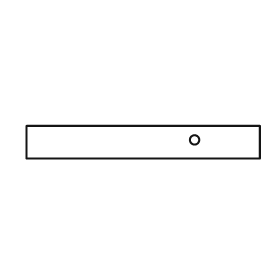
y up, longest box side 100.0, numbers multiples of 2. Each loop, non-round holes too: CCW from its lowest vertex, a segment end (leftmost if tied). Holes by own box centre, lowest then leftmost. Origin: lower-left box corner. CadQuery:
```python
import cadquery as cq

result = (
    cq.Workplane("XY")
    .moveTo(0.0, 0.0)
    .lineTo(100.0, 0.0)
    .lineTo(100.0, 14.0)
    .lineTo(0.0, 14.0)
    .close()
    .moveTo(72.0, 8.0)
    .circle(2.0)
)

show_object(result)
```